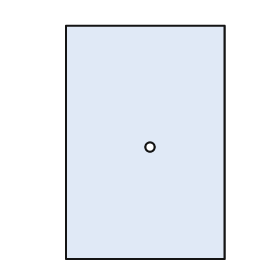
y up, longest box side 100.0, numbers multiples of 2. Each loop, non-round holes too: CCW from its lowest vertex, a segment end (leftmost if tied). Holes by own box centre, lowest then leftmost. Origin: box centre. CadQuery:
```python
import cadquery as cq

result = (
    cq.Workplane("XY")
    .moveTo(-34.0, -50.0)
    .lineTo(34.0, -50.0)
    .lineTo(34.0, 50.0)
    .lineTo(-34.0, 50.0)
    .close()
    .moveTo(2.0, -2.0)
    .circle(2.0)
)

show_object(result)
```